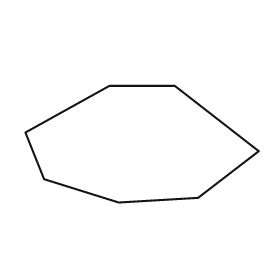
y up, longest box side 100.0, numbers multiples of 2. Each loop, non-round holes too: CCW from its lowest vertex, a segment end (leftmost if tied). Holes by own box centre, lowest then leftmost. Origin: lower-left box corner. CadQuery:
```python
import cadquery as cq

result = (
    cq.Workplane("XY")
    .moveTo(40.0, 0.0)
    .lineTo(74.0, 2.0)
    .lineTo(100.0, 22.0)
    .lineTo(64.0, 50.0)
    .lineTo(36.0, 50.0)
    .lineTo(0.0, 30.0)
    .lineTo(8.0, 10.0)
    .close()
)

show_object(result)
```